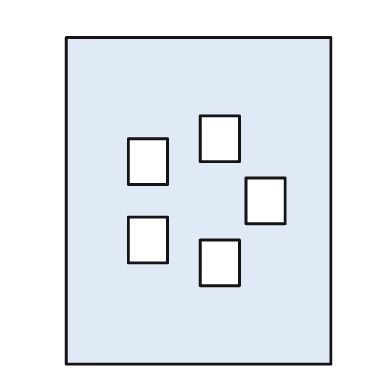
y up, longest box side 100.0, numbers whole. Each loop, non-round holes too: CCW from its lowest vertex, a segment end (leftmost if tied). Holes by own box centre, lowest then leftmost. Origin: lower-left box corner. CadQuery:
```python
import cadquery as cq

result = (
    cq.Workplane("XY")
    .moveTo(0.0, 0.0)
    .lineTo(81.0, 0.0)
    .lineTo(81.0, 100.0)
    .lineTo(0.0, 100.0)
    .close()
    .moveTo(41.0, 24.0)
    .lineTo(53.0, 24.0)
    .lineTo(53.0, 38.0)
    .lineTo(41.0, 38.0)
    .close()
    .moveTo(19.0, 31.0)
    .lineTo(31.0, 31.0)
    .lineTo(31.0, 45.0)
    .lineTo(19.0, 45.0)
    .close()
    .moveTo(55.0, 43.0)
    .lineTo(67.0, 43.0)
    .lineTo(67.0, 57.0)
    .lineTo(55.0, 57.0)
    .close()
    .moveTo(19.0, 55.0)
    .lineTo(31.0, 55.0)
    .lineTo(31.0, 69.0)
    .lineTo(19.0, 69.0)
    .close()
    .moveTo(41.0, 62.0)
    .lineTo(53.0, 62.0)
    .lineTo(53.0, 76.0)
    .lineTo(41.0, 76.0)
    .close()
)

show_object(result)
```